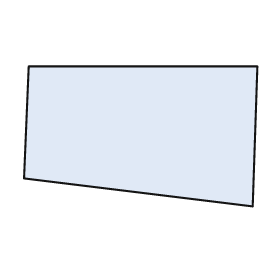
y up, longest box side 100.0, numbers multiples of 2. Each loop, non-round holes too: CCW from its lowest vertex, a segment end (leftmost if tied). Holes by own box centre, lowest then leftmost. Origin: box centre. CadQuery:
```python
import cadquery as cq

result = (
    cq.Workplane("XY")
    .moveTo(48.0, -30.0)
    .lineTo(50.0, 30.0)
    .lineTo(-48.0, 30.0)
    .lineTo(-50.0, -18.0)
    .close()
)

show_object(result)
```